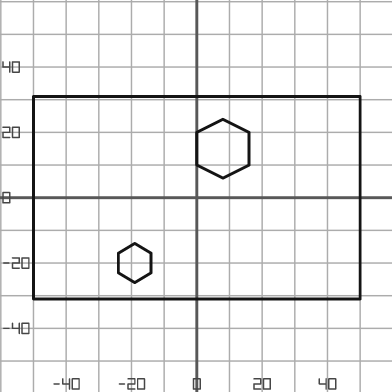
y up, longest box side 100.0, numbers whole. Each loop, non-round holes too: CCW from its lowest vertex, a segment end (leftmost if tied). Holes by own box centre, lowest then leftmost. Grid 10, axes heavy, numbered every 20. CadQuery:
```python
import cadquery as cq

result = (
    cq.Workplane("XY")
    .moveTo(-50.0, -31.0)
    .lineTo(50.0, -31.0)
    .lineTo(50.0, 31.0)
    .lineTo(-50.0, 31.0)
    .close()
    .moveTo(-19.0, -26.0)
    .lineTo(-14.0, -23.0)
    .lineTo(-14.0, -17.0)
    .lineTo(-19.0, -14.0)
    .lineTo(-24.0, -17.0)
    .lineTo(-24.0, -23.0)
    .close()
    .moveTo(8.0, 6.0)
    .lineTo(16.0, 10.0)
    .lineTo(16.0, 20.0)
    .lineTo(8.0, 24.0)
    .lineTo(0.0, 20.0)
    .lineTo(0.0, 10.0)
    .close()
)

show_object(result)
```